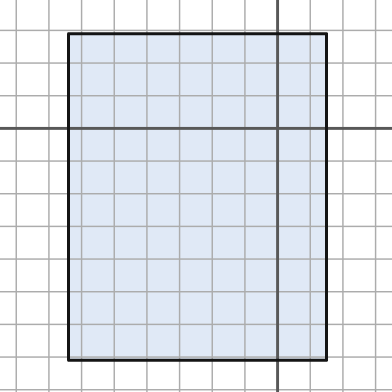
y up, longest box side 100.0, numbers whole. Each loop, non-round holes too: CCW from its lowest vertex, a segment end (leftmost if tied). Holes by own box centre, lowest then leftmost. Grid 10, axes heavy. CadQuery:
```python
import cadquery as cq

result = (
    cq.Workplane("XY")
    .moveTo(-64.0, -71.0)
    .lineTo(15.0, -71.0)
    .lineTo(15.0, 29.0)
    .lineTo(-64.0, 29.0)
    .close()
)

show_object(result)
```